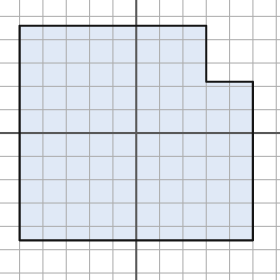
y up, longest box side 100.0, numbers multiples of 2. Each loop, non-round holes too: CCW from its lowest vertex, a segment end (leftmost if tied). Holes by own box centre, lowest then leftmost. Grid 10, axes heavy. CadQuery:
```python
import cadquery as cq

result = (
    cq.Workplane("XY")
    .moveTo(-50.0, -46.0)
    .lineTo(50.0, -46.0)
    .lineTo(50.0, 22.0)
    .lineTo(30.0, 22.0)
    .lineTo(30.0, 46.0)
    .lineTo(-50.0, 46.0)
    .close()
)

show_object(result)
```